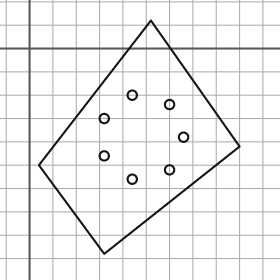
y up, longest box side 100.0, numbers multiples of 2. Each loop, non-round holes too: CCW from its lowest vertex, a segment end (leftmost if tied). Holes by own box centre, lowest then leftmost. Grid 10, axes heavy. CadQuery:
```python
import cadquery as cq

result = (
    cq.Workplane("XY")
    .moveTo(32.0, -88.0)
    .lineTo(90.0, -42.0)
    .lineTo(52.0, 12.0)
    .lineTo(4.0, -50.0)
    .close()
    .moveTo(44.0, -56.0)
    .circle(2.0)
    .moveTo(60.0, -52.0)
    .circle(2.0)
    .moveTo(32.0, -46.0)
    .circle(2.0)
    .moveTo(66.0, -38.0)
    .circle(2.0)
    .moveTo(32.0, -30.0)
    .circle(2.0)
    .moveTo(60.0, -24.0)
    .circle(2.0)
    .moveTo(44.0, -20.0)
    .circle(2.0)
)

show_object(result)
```